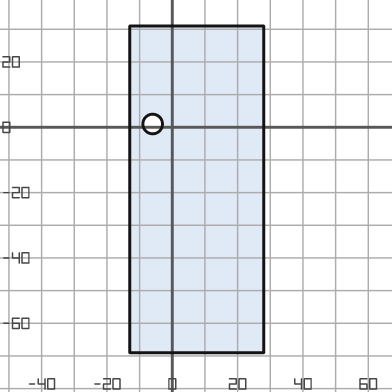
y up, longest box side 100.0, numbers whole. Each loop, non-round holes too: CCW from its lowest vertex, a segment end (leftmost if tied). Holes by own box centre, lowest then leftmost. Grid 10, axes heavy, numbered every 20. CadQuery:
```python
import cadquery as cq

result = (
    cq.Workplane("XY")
    .moveTo(-13.0, -69.0)
    .lineTo(28.0, -69.0)
    .lineTo(28.0, 31.0)
    .lineTo(-13.0, 31.0)
    .close()
    .moveTo(-6.0, 1.0)
    .circle(3.0)
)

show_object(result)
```